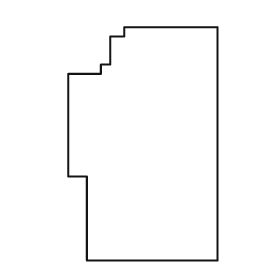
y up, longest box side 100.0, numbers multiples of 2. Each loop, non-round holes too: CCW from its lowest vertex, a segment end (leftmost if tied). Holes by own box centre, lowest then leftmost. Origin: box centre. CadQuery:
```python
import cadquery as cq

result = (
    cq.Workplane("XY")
    .moveTo(-24.0, -50.0)
    .lineTo(32.0, -50.0)
    .lineTo(32.0, 50.0)
    .lineTo(-8.0, 50.0)
    .lineTo(-8.0, 46.0)
    .lineTo(-14.0, 46.0)
    .lineTo(-14.0, 34.0)
    .lineTo(-18.0, 34.0)
    .lineTo(-18.0, 30.0)
    .lineTo(-32.0, 30.0)
    .lineTo(-32.0, -14.0)
    .lineTo(-24.0, -14.0)
    .close()
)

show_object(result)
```